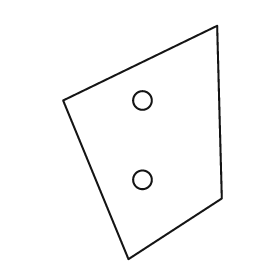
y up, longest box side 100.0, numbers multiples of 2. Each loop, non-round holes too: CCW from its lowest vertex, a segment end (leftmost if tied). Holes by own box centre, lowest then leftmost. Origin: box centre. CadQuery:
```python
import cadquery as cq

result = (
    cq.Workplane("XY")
    .moveTo(-6.0, -50.0)
    .lineTo(34.0, -24.0)
    .lineTo(32.0, 50.0)
    .lineTo(-34.0, 18.0)
    .close()
    .moveTo(0.0, -16.0)
    .circle(4.0)
    .moveTo(0.0, 18.0)
    .circle(4.0)
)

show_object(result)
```